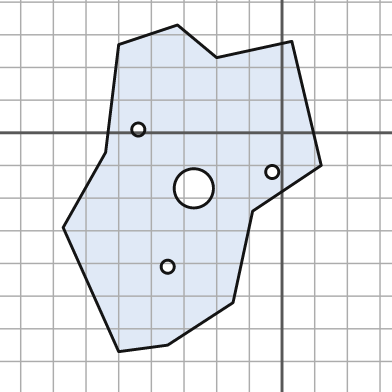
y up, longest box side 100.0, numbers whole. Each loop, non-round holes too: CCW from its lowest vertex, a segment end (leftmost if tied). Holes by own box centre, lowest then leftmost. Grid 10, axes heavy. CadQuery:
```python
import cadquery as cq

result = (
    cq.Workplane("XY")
    .moveTo(-50.0, -67.0)
    .lineTo(-35.0, -65.0)
    .lineTo(-15.0, -52.0)
    .lineTo(-9.0, -24.0)
    .lineTo(12.0, -10.0)
    .lineTo(3.0, 28.0)
    .lineTo(-20.0, 23.0)
    .lineTo(-32.0, 33.0)
    .lineTo(-50.0, 27.0)
    .lineTo(-54.0, -6.0)
    .lineTo(-67.0, -29.0)
    .close()
    .moveTo(-35.0, -41.0)
    .circle(2.0)
    .moveTo(-27.0, -17.0)
    .circle(6.0)
    .moveTo(-3.0, -12.0)
    .circle(2.0)
    .moveTo(-44.0, 1.0)
    .circle(2.0)
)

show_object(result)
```